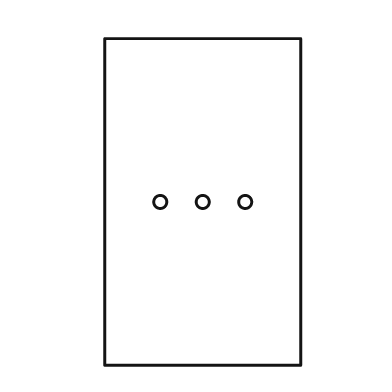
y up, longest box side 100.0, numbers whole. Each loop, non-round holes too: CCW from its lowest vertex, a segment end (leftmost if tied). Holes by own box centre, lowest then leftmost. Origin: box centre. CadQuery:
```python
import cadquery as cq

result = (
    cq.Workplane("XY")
    .moveTo(-30.0, -50.0)
    .lineTo(30.0, -50.0)
    .lineTo(30.0, 50.0)
    .lineTo(-30.0, 50.0)
    .close()
    .moveTo(-13.0, 0.0)
    .circle(2.0)
    .moveTo(0.0, 0.0)
    .circle(2.0)
    .moveTo(13.0, 0.0)
    .circle(2.0)
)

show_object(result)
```